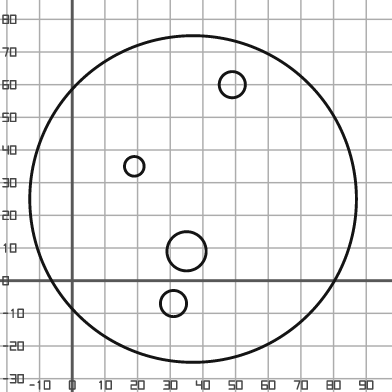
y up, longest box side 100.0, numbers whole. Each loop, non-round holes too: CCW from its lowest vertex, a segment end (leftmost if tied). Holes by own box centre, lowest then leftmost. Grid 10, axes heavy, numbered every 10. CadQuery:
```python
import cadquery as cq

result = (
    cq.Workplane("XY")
    .moveTo(37.0, 25.0)
    .circle(50.0)
    .moveTo(31.0, -7.0)
    .circle(4.0)
    .moveTo(35.0, 9.0)
    .circle(6.0)
    .moveTo(19.0, 35.0)
    .circle(3.0)
    .moveTo(49.0, 60.0)
    .circle(4.0)
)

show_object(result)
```